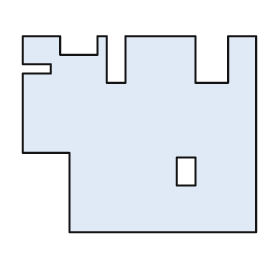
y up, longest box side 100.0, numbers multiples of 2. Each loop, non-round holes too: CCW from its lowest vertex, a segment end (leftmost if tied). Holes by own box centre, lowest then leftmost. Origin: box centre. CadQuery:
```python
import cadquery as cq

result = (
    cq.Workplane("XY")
    .moveTo(-30.0, -42.0)
    .lineTo(50.0, -42.0)
    .lineTo(50.0, 42.0)
    .lineTo(38.0, 42.0)
    .lineTo(38.0, 22.0)
    .lineTo(24.0, 22.0)
    .lineTo(24.0, 42.0)
    .lineTo(-6.0, 42.0)
    .lineTo(-6.0, 22.0)
    .lineTo(-14.0, 22.0)
    .lineTo(-14.0, 42.0)
    .lineTo(-18.0, 42.0)
    .lineTo(-18.0, 34.0)
    .lineTo(-34.0, 34.0)
    .lineTo(-34.0, 42.0)
    .lineTo(-50.0, 42.0)
    .lineTo(-50.0, 30.0)
    .lineTo(-38.0, 30.0)
    .lineTo(-38.0, 26.0)
    .lineTo(-50.0, 26.0)
    .lineTo(-50.0, -8.0)
    .lineTo(-30.0, -8.0)
    .close()
    .moveTo(16.0, -22.0)
    .lineTo(24.0, -22.0)
    .lineTo(24.0, -10.0)
    .lineTo(16.0, -10.0)
    .close()
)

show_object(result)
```